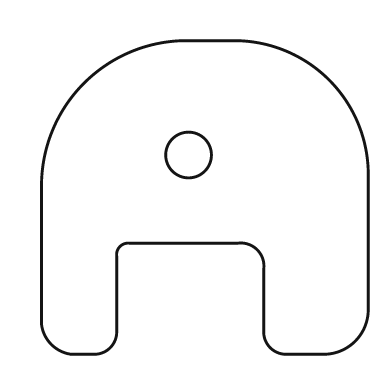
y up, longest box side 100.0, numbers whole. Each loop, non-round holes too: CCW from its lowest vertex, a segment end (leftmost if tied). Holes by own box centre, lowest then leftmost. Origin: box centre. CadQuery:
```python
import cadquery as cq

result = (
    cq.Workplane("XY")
    .moveTo(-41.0, -48.0)
    .lineTo(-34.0, -48.0)
    .threePointArc((-29.0, -46.0), (-27.0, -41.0))
    .lineTo(-27.0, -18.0)
    .threePointArc((-26.0, -15.0), (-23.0, -14.0))
    .lineTo(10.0, -14.0)
    .threePointArc((16.0, -16.0), (18.0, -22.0))
    .lineTo(18.0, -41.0)
    .threePointArc((20.0, -46.0), (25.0, -48.0))
    .lineTo(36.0, -48.0)
    .threePointArc((46.0, -44.0), (50.0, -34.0))
    .lineTo(50.0, 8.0)
    .threePointArc((38.0, 36.0), (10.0, 48.0))
    .lineTo(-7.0, 48.0)
    .threePointArc((-37.0, 35.0), (-50.0, 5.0))
    .lineTo(-50.0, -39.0)
    .threePointArc((-47.0, -45.0), (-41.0, -48.0))
    .close()
    .moveTo(-5.0, 13.0)
    .circle(7.0)
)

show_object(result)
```